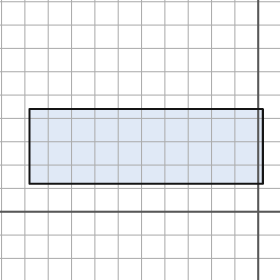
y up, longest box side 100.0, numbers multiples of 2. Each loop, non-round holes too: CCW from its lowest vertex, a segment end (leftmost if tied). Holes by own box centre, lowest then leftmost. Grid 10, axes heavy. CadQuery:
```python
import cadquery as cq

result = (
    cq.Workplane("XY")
    .moveTo(-98.0, 12.0)
    .lineTo(2.0, 12.0)
    .lineTo(2.0, 44.0)
    .lineTo(-98.0, 44.0)
    .close()
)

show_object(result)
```